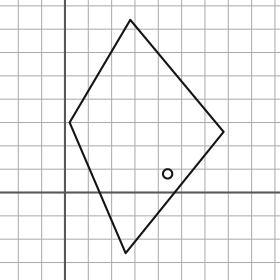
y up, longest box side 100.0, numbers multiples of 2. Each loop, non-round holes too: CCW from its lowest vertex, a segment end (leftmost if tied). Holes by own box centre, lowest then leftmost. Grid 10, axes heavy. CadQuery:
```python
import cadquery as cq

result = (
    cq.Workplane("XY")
    .moveTo(26.0, -26.0)
    .lineTo(68.0, 26.0)
    .lineTo(28.0, 74.0)
    .lineTo(2.0, 30.0)
    .close()
    .moveTo(44.0, 8.0)
    .circle(2.0)
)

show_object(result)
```